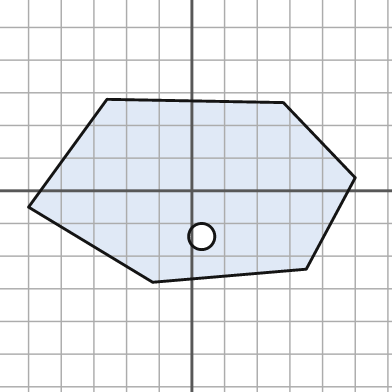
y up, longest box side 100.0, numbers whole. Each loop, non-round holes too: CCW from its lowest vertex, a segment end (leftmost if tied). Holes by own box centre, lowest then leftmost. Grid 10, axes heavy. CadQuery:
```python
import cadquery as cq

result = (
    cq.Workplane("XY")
    .moveTo(-12.0, -28.0)
    .lineTo(35.0, -24.0)
    .lineTo(50.0, 4.0)
    .lineTo(28.0, 27.0)
    .lineTo(-26.0, 28.0)
    .lineTo(-50.0, -5.0)
    .close()
    .moveTo(3.0, -14.0)
    .circle(4.0)
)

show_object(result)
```